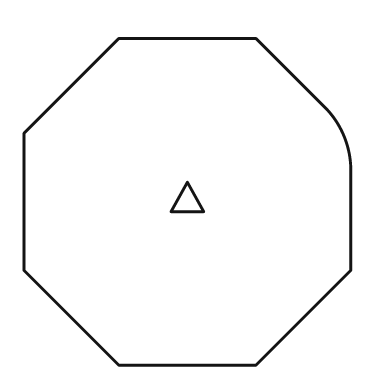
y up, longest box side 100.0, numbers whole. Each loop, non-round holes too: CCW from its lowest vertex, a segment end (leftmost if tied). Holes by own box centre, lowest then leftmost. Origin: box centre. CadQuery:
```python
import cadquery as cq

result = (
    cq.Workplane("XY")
    .moveTo(-21.0, -50.0)
    .lineTo(21.0, -50.0)
    .lineTo(50.0, -21.0)
    .lineTo(50.0, 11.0)
    .threePointArc((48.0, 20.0), (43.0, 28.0))
    .lineTo(21.0, 50.0)
    .lineTo(-21.0, 50.0)
    .lineTo(-50.0, 21.0)
    .lineTo(-50.0, -21.0)
    .close()
    .moveTo(-5.0, -3.0)
    .lineTo(5.0, -3.0)
    .lineTo(0.0, 6.0)
    .close()
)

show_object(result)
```